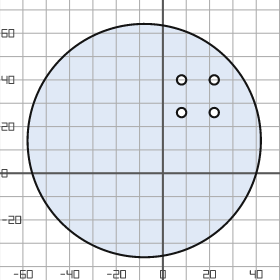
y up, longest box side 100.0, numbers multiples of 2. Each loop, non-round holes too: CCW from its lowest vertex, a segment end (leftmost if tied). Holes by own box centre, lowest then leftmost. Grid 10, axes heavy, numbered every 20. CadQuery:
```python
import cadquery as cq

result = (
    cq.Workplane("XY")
    .moveTo(-8.0, 14.0)
    .circle(50.0)
    .moveTo(8.0, 26.0)
    .circle(2.0)
    .moveTo(22.0, 26.0)
    .circle(2.0)
    .moveTo(8.0, 40.0)
    .circle(2.0)
    .moveTo(22.0, 40.0)
    .circle(2.0)
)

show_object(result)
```